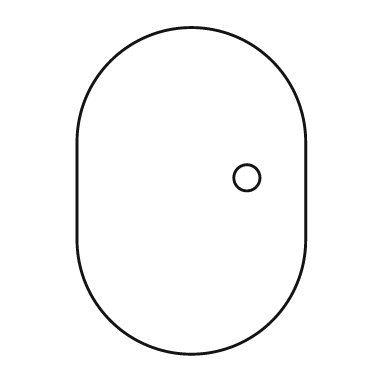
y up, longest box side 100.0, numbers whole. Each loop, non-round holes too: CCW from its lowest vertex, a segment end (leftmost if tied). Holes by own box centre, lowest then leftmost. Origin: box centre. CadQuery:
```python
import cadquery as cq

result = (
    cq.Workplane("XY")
    .moveTo(-35.0, -15.0)
    .threePointArc((0.0, -50.0), (35.0, -15.0))
    .lineTo(35.0, 15.0)
    .threePointArc((0.0, 50.0), (-35.0, 15.0))
    .close()
    .moveTo(17.0, 4.0)
    .circle(4.0)
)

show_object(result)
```